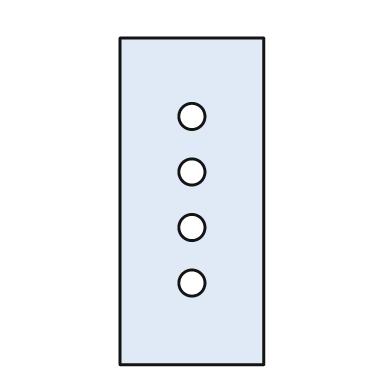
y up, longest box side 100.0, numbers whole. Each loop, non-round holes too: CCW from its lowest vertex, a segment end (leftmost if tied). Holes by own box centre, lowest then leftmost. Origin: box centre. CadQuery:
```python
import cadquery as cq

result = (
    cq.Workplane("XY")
    .moveTo(-22.0, -50.0)
    .lineTo(22.0, -50.0)
    .lineTo(22.0, 50.0)
    .lineTo(-22.0, 50.0)
    .close()
    .moveTo(0.0, -25.0)
    .circle(4.0)
    .moveTo(0.0, -8.0)
    .circle(4.0)
    .moveTo(0.0, 9.0)
    .circle(4.0)
    .moveTo(0.0, 26.0)
    .circle(4.0)
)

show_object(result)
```